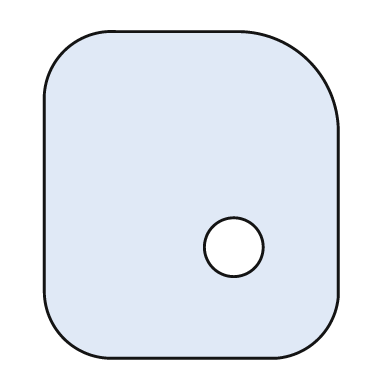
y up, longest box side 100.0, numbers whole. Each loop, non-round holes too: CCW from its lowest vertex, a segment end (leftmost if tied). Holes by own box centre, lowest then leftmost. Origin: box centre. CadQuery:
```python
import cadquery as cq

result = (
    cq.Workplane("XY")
    .moveTo(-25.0, -50.0)
    .lineTo(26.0, -50.0)
    .threePointArc((39.0, -44.0), (45.0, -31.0))
    .lineTo(45.0, 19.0)
    .threePointArc((36.0, 41.0), (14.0, 50.0))
    .lineTo(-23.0, 50.0)
    .threePointArc((-39.0, 44.0), (-45.0, 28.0))
    .lineTo(-45.0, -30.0)
    .threePointArc((-39.0, -44.0), (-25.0, -50.0))
    .close()
    .moveTo(13.0, -16.0)
    .circle(9.0)
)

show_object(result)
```